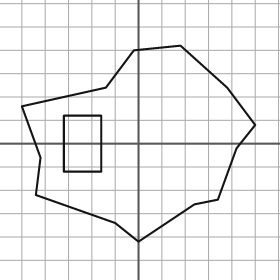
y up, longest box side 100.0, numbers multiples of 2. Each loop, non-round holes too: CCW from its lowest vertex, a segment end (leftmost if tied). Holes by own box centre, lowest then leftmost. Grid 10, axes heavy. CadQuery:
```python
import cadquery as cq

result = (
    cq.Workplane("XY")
    .moveTo(0.0, -42.0)
    .lineTo(24.0, -26.0)
    .lineTo(34.0, -24.0)
    .lineTo(42.0, -2.0)
    .lineTo(50.0, 8.0)
    .lineTo(38.0, 24.0)
    .lineTo(18.0, 42.0)
    .lineTo(-2.0, 40.0)
    .lineTo(-14.0, 24.0)
    .lineTo(-50.0, 16.0)
    .lineTo(-42.0, -6.0)
    .lineTo(-44.0, -22.0)
    .lineTo(-10.0, -34.0)
    .close()
    .moveTo(-32.0, -12.0)
    .lineTo(-16.0, -12.0)
    .lineTo(-16.0, 12.0)
    .lineTo(-32.0, 12.0)
    .close()
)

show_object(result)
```